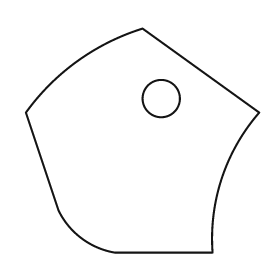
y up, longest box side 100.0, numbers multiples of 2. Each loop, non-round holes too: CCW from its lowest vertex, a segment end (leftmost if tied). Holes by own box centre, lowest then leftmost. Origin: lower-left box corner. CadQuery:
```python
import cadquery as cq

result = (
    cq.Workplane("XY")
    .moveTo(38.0, 0.0)
    .lineTo(80.0, 0.0)
    .threePointArc((84.0, 32.0), (100.0, 60.0))
    .lineTo(50.0, 96.0)
    .threePointArc((22.0, 82.0), (0.0, 60.0))
    .lineTo(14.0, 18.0)
    .threePointArc((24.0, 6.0), (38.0, 0.0))
    .close()
    .moveTo(58.0, 66.0)
    .circle(8.0)
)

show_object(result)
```